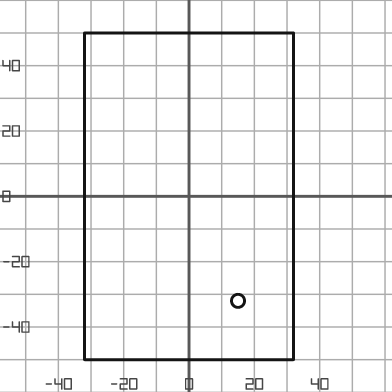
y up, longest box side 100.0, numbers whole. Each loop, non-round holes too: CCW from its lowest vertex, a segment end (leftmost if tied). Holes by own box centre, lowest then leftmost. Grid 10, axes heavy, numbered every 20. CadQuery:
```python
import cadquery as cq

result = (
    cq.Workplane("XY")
    .moveTo(-32.0, -50.0)
    .lineTo(32.0, -50.0)
    .lineTo(32.0, 50.0)
    .lineTo(-32.0, 50.0)
    .close()
    .moveTo(15.0, -32.0)
    .circle(2.0)
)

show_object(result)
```